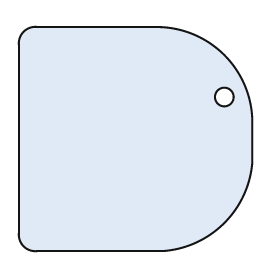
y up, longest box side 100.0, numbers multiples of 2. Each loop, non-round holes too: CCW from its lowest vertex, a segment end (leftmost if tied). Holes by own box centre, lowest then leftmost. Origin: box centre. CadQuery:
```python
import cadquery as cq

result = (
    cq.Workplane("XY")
    .moveTo(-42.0, -48.0)
    .lineTo(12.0, -48.0)
    .threePointArc((38.0, -36.0), (50.0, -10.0))
    .lineTo(50.0, 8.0)
    .threePointArc((38.0, 36.0), (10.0, 48.0))
    .lineTo(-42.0, 48.0)
    .threePointArc((-48.0, 46.0), (-50.0, 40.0))
    .lineTo(-50.0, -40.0)
    .threePointArc((-48.0, -46.0), (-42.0, -48.0))
    .close()
    .moveTo(38.0, 18.0)
    .circle(4.0)
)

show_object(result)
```